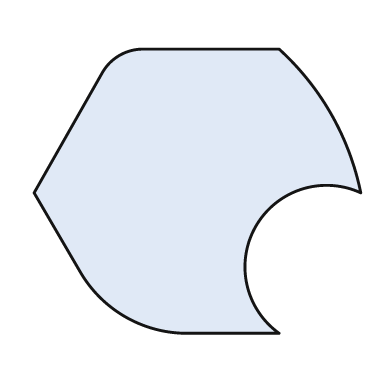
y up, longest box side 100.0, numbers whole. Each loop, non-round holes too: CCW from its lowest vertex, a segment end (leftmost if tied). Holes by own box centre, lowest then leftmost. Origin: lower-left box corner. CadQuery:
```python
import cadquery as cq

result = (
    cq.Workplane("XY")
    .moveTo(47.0, 0.0)
    .lineTo(75.0, 0.0)
    .threePointArc((68.0, 33.0), (100.0, 43.0))
    .threePointArc((91.0, 67.0), (75.0, 87.0))
    .lineTo(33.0, 87.0)
    .threePointArc((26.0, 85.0), (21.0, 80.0))
    .lineTo(0.0, 43.0)
    .lineTo(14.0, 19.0)
    .threePointArc((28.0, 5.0), (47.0, 0.0))
    .close()
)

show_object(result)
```